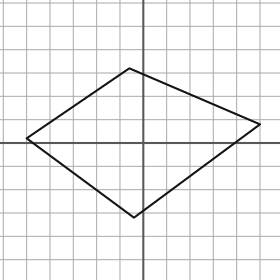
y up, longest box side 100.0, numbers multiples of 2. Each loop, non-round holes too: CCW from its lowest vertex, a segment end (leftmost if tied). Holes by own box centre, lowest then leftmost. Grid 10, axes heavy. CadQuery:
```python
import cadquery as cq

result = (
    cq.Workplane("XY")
    .moveTo(-4.0, -32.0)
    .lineTo(50.0, 8.0)
    .lineTo(-6.0, 32.0)
    .lineTo(-50.0, 2.0)
    .close()
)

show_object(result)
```